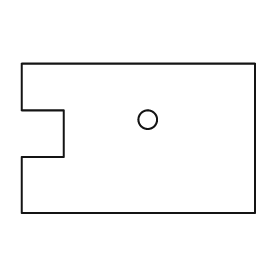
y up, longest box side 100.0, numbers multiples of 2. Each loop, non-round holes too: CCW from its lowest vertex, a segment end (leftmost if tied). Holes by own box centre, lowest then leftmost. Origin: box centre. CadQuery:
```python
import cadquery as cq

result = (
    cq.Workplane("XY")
    .moveTo(-50.0, -32.0)
    .lineTo(50.0, -32.0)
    .lineTo(50.0, 32.0)
    .lineTo(-50.0, 32.0)
    .lineTo(-50.0, 12.0)
    .lineTo(-32.0, 12.0)
    .lineTo(-32.0, -8.0)
    .lineTo(-50.0, -8.0)
    .close()
    .moveTo(4.0, 8.0)
    .circle(4.0)
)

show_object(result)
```